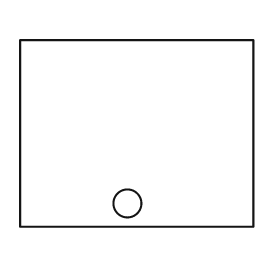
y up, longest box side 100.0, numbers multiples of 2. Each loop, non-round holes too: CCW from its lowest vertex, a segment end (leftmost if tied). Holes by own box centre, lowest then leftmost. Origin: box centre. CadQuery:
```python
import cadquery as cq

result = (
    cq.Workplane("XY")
    .moveTo(-50.0, -40.0)
    .lineTo(50.0, -40.0)
    .lineTo(50.0, 40.0)
    .lineTo(-50.0, 40.0)
    .close()
    .moveTo(-4.0, -30.0)
    .circle(6.0)
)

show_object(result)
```